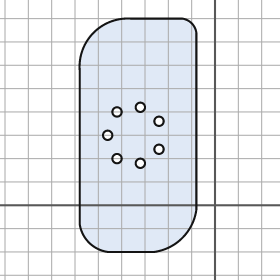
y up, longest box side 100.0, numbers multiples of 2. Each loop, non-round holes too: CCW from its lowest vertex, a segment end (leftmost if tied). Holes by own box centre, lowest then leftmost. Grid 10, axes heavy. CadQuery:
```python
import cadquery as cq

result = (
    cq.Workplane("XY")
    .moveTo(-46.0, -20.0)
    .lineTo(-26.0, -20.0)
    .threePointArc((-14.0, -14.0), (-8.0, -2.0))
    .lineTo(-8.0, 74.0)
    .threePointArc((-10.0, 78.0), (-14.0, 80.0))
    .lineTo(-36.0, 80.0)
    .threePointArc((-52.0, 74.0), (-58.0, 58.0))
    .lineTo(-58.0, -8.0)
    .threePointArc((-54.0, -16.0), (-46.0, -20.0))
    .close()
    .moveTo(-32.0, 18.0)
    .circle(2.0)
    .moveTo(-42.0, 20.0)
    .circle(2.0)
    .moveTo(-24.0, 24.0)
    .circle(2.0)
    .moveTo(-46.0, 30.0)
    .circle(2.0)
    .moveTo(-24.0, 36.0)
    .circle(2.0)
    .moveTo(-42.0, 40.0)
    .circle(2.0)
    .moveTo(-32.0, 42.0)
    .circle(2.0)
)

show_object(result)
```